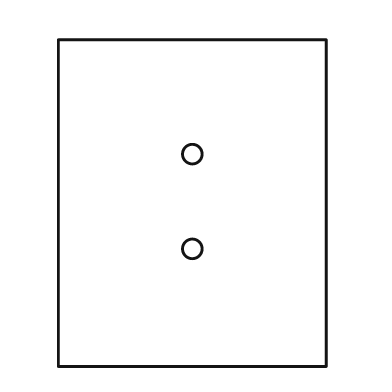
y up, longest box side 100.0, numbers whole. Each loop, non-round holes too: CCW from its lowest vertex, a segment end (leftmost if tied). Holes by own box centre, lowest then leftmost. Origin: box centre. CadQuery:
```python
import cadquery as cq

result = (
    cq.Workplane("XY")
    .moveTo(-41.0, -50.0)
    .lineTo(41.0, -50.0)
    .lineTo(41.0, 50.0)
    .lineTo(-41.0, 50.0)
    .close()
    .moveTo(0.0, -14.0)
    .circle(3.0)
    .moveTo(0.0, 15.0)
    .circle(3.0)
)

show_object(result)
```